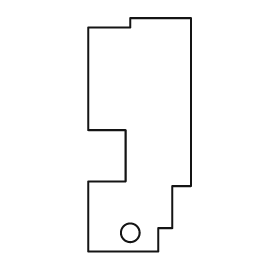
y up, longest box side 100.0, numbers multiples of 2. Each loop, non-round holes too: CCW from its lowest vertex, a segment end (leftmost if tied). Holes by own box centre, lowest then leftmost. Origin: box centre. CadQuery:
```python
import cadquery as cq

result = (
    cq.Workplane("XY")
    .moveTo(-22.0, -50.0)
    .lineTo(8.0, -50.0)
    .lineTo(8.0, -40.0)
    .lineTo(14.0, -40.0)
    .lineTo(14.0, -22.0)
    .lineTo(22.0, -22.0)
    .lineTo(22.0, 50.0)
    .lineTo(-4.0, 50.0)
    .lineTo(-4.0, 46.0)
    .lineTo(-22.0, 46.0)
    .lineTo(-22.0, 2.0)
    .lineTo(-6.0, 2.0)
    .lineTo(-6.0, -20.0)
    .lineTo(-22.0, -20.0)
    .close()
    .moveTo(-4.0, -42.0)
    .circle(4.0)
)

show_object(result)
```